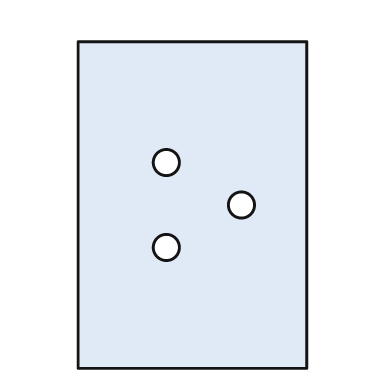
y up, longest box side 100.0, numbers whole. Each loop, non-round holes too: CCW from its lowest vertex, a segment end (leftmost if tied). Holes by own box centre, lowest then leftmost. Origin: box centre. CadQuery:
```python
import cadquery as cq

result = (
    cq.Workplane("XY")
    .moveTo(-35.0, -50.0)
    .lineTo(35.0, -50.0)
    .lineTo(35.0, 50.0)
    .lineTo(-35.0, 50.0)
    .close()
    .moveTo(-8.0, -13.0)
    .circle(4.0)
    .moveTo(15.0, 0.0)
    .circle(4.0)
    .moveTo(-8.0, 13.0)
    .circle(4.0)
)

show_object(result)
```